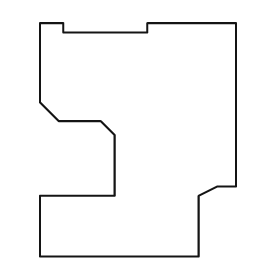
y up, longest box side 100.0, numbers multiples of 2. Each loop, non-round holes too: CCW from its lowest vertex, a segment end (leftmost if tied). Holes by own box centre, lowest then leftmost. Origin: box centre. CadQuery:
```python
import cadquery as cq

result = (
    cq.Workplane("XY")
    .moveTo(-42.0, -50.0)
    .lineTo(26.0, -50.0)
    .lineTo(26.0, -24.0)
    .lineTo(34.0, -20.0)
    .lineTo(42.0, -20.0)
    .lineTo(42.0, 50.0)
    .lineTo(4.0, 50.0)
    .lineTo(4.0, 46.0)
    .lineTo(-32.0, 46.0)
    .lineTo(-32.0, 50.0)
    .lineTo(-42.0, 50.0)
    .lineTo(-42.0, 16.0)
    .lineTo(-34.0, 8.0)
    .lineTo(-16.0, 8.0)
    .lineTo(-10.0, 2.0)
    .lineTo(-10.0, -24.0)
    .lineTo(-42.0, -24.0)
    .close()
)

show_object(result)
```